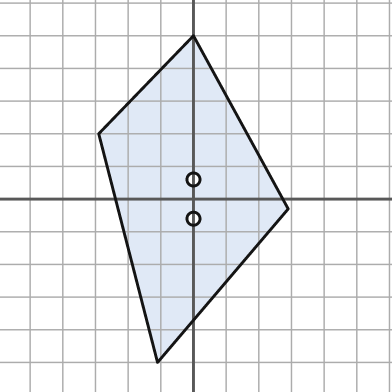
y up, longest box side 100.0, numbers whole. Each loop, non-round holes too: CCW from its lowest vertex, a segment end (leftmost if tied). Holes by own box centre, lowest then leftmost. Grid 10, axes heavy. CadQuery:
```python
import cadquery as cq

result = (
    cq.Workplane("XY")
    .moveTo(-11.0, -50.0)
    .lineTo(29.0, -3.0)
    .lineTo(0.0, 50.0)
    .lineTo(-29.0, 20.0)
    .close()
    .moveTo(0.0, -6.0)
    .circle(2.0)
    .moveTo(0.0, 6.0)
    .circle(2.0)
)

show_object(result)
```